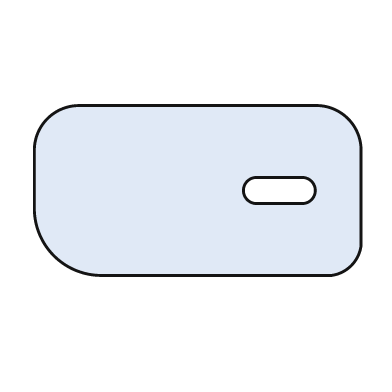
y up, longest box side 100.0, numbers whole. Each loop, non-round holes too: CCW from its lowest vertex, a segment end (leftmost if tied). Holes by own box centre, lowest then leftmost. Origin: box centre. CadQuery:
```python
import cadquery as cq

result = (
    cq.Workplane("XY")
    .moveTo(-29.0, -26.0)
    .lineTo(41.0, -26.0)
    .threePointArc((47.0, -23.0), (50.0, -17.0))
    .lineTo(50.0, 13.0)
    .threePointArc((46.0, 22.0), (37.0, 26.0))
    .lineTo(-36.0, 26.0)
    .threePointArc((-46.0, 22.0), (-50.0, 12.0))
    .lineTo(-50.0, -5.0)
    .threePointArc((-44.0, -20.0), (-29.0, -26.0))
    .close()
    .moveTo(18.0, -4.0)
    .lineTo(32.0, -4.0)
    .threePointArc((36.0, 0.0), (32.0, 4.0))
    .lineTo(18.0, 4.0)
    .threePointArc((14.0, 0.0), (18.0, -4.0))
    .close()
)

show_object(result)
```